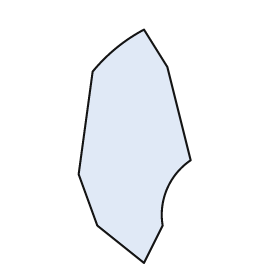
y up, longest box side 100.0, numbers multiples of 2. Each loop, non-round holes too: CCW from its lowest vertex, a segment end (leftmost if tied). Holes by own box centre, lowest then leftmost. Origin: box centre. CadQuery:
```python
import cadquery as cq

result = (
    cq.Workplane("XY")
    .moveTo(4.0, -50.0)
    .lineTo(12.0, -34.0)
    .threePointArc((14.0, -18.0), (24.0, -6.0))
    .lineTo(14.0, 34.0)
    .lineTo(4.0, 50.0)
    .threePointArc((-8.0, 42.0), (-18.0, 32.0))
    .lineTo(-24.0, -12.0)
    .lineTo(-16.0, -34.0)
    .close()
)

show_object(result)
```